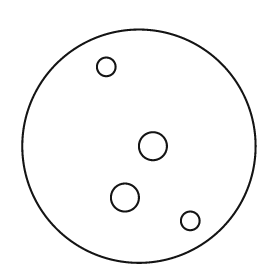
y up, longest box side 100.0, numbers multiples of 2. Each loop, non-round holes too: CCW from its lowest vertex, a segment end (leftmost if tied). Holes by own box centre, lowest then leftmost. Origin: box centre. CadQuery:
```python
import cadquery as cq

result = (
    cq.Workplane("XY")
    .moveTo(0.0, 0.0)
    .circle(50.0)
    .moveTo(22.0, -32.0)
    .circle(4.0)
    .moveTo(-6.0, -22.0)
    .circle(6.0)
    .moveTo(6.0, 0.0)
    .circle(6.0)
    .moveTo(-14.0, 34.0)
    .circle(4.0)
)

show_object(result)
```